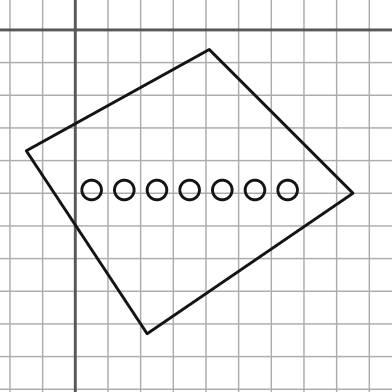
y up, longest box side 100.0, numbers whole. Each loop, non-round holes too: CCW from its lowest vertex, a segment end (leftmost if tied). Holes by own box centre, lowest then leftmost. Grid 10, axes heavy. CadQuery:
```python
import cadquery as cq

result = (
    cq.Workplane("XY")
    .moveTo(22.0, -93.0)
    .lineTo(85.0, -50.0)
    .lineTo(41.0, -6.0)
    .lineTo(-15.0, -37.0)
    .close()
    .moveTo(5.0, -49.0)
    .circle(3.0)
    .moveTo(15.0, -49.0)
    .circle(3.0)
    .moveTo(25.0, -49.0)
    .circle(3.0)
    .moveTo(35.0, -49.0)
    .circle(3.0)
    .moveTo(45.0, -49.0)
    .circle(3.0)
    .moveTo(55.0, -49.0)
    .circle(3.0)
    .moveTo(65.0, -49.0)
    .circle(3.0)
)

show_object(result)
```